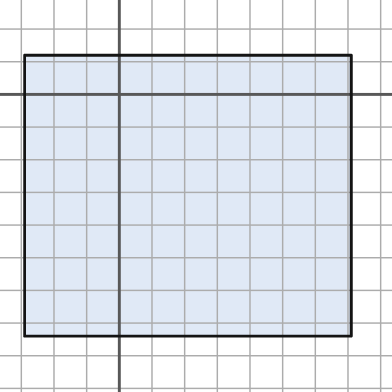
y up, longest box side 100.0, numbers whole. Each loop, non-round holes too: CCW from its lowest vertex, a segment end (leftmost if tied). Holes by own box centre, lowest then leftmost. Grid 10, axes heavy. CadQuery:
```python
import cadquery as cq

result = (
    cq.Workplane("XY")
    .moveTo(-29.0, -74.0)
    .lineTo(71.0, -74.0)
    .lineTo(71.0, 12.0)
    .lineTo(-29.0, 12.0)
    .close()
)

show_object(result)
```